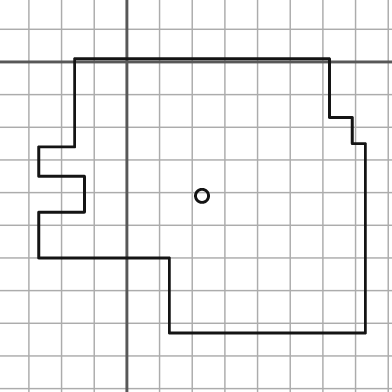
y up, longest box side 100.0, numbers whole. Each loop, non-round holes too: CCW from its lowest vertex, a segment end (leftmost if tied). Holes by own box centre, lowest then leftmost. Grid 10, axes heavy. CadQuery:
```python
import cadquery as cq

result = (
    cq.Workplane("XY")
    .moveTo(13.0, -83.0)
    .lineTo(73.0, -83.0)
    .lineTo(73.0, -25.0)
    .lineTo(69.0, -25.0)
    .lineTo(69.0, -17.0)
    .lineTo(62.0, -17.0)
    .lineTo(62.0, 1.0)
    .lineTo(-16.0, 1.0)
    .lineTo(-16.0, -26.0)
    .lineTo(-27.0, -26.0)
    .lineTo(-27.0, -35.0)
    .lineTo(-13.0, -35.0)
    .lineTo(-13.0, -46.0)
    .lineTo(-27.0, -46.0)
    .lineTo(-27.0, -60.0)
    .lineTo(13.0, -60.0)
    .close()
    .moveTo(23.0, -41.0)
    .circle(2.0)
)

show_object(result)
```